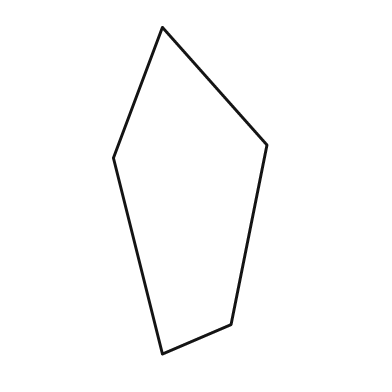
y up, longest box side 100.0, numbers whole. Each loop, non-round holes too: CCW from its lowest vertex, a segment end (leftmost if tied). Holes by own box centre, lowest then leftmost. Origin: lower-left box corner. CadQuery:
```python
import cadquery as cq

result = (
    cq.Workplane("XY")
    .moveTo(15.0, 0.0)
    .lineTo(36.0, 9.0)
    .lineTo(47.0, 64.0)
    .lineTo(15.0, 100.0)
    .lineTo(0.0, 60.0)
    .close()
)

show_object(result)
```